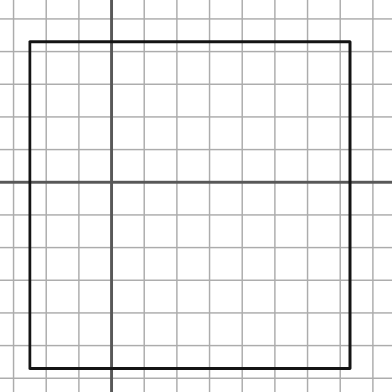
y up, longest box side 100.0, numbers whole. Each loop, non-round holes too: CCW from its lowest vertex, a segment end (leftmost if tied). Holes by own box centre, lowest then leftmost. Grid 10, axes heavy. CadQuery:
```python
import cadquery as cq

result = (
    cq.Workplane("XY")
    .moveTo(-25.0, -57.0)
    .lineTo(73.0, -57.0)
    .lineTo(73.0, 43.0)
    .lineTo(-25.0, 43.0)
    .close()
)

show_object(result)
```